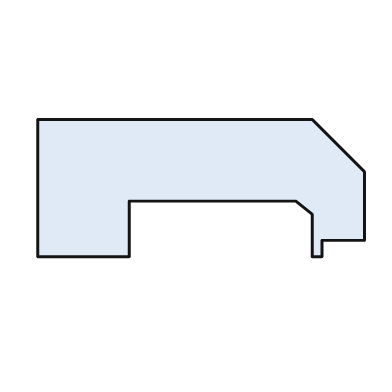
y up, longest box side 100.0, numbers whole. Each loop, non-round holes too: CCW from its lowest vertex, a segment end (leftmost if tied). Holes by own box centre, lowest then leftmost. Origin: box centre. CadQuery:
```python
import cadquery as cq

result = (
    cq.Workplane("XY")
    .moveTo(-50.0, -21.0)
    .lineTo(-22.0, -21.0)
    .lineTo(-22.0, -4.0)
    .lineTo(29.0, -4.0)
    .lineTo(34.0, -8.0)
    .lineTo(34.0, -21.0)
    .lineTo(37.0, -21.0)
    .lineTo(37.0, -16.0)
    .lineTo(50.0, -16.0)
    .lineTo(50.0, 5.0)
    .lineTo(34.0, 21.0)
    .lineTo(-50.0, 21.0)
    .close()
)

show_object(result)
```